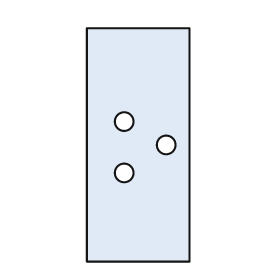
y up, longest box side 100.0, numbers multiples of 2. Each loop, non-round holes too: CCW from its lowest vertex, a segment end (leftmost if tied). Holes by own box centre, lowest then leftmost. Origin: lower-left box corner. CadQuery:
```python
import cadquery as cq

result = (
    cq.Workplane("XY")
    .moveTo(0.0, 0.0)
    .lineTo(44.0, 0.0)
    .lineTo(44.0, 100.0)
    .lineTo(0.0, 100.0)
    .close()
    .moveTo(16.0, 38.0)
    .circle(4.0)
    .moveTo(34.0, 50.0)
    .circle(4.0)
    .moveTo(16.0, 60.0)
    .circle(4.0)
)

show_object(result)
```